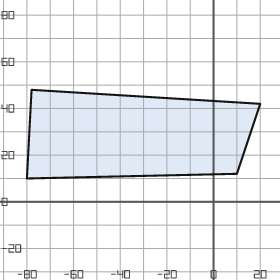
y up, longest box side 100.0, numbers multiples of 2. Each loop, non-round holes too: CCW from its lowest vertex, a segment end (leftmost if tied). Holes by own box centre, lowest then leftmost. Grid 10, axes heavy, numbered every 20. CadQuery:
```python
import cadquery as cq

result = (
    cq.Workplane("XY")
    .moveTo(-80.0, 10.0)
    .lineTo(10.0, 12.0)
    .lineTo(20.0, 42.0)
    .lineTo(-78.0, 48.0)
    .close()
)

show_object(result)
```